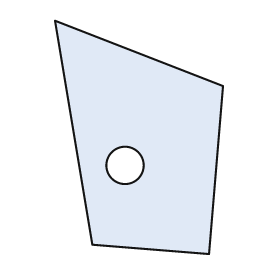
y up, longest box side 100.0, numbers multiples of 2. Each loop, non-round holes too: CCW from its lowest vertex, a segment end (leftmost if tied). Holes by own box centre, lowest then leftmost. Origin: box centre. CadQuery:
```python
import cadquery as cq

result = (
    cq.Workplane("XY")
    .moveTo(30.0, -50.0)
    .lineTo(36.0, 22.0)
    .lineTo(-36.0, 50.0)
    .lineTo(-20.0, -46.0)
    .close()
    .moveTo(-6.0, -12.0)
    .circle(8.0)
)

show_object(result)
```